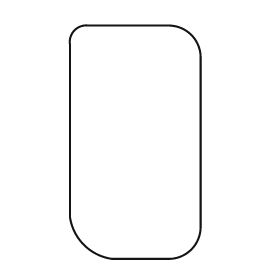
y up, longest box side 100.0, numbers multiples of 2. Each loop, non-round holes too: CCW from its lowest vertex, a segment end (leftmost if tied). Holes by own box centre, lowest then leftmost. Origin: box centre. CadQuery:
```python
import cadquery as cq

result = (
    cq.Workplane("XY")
    .moveTo(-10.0, -50.0)
    .lineTo(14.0, -50.0)
    .threePointArc((24.0, -46.0), (28.0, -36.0))
    .lineTo(28.0, 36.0)
    .threePointArc((24.0, 46.0), (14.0, 50.0))
    .lineTo(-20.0, 50.0)
    .threePointArc((-26.0, 48.0), (-28.0, 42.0))
    .lineTo(-28.0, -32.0)
    .threePointArc((-22.0, -44.0), (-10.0, -50.0))
    .close()
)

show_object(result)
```